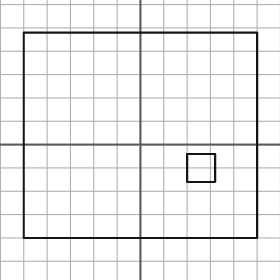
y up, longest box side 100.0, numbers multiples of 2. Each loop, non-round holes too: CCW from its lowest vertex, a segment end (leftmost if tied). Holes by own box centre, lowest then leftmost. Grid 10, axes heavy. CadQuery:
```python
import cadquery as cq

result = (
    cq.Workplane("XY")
    .moveTo(-50.0, -40.0)
    .lineTo(50.0, -40.0)
    .lineTo(50.0, 48.0)
    .lineTo(-50.0, 48.0)
    .close()
    .moveTo(20.0, -16.0)
    .lineTo(32.0, -16.0)
    .lineTo(32.0, -4.0)
    .lineTo(20.0, -4.0)
    .close()
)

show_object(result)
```